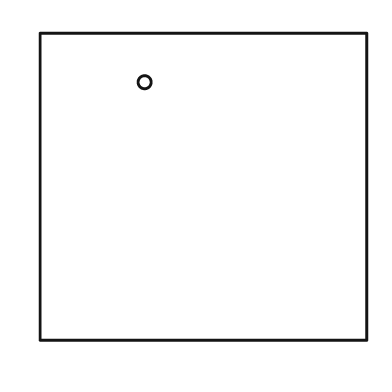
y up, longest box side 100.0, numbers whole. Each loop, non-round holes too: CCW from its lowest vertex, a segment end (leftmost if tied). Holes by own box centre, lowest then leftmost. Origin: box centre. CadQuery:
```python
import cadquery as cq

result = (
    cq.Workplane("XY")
    .moveTo(-50.0, -47.0)
    .lineTo(50.0, -47.0)
    .lineTo(50.0, 47.0)
    .lineTo(-50.0, 47.0)
    .close()
    .moveTo(-18.0, 32.0)
    .circle(2.0)
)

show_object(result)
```